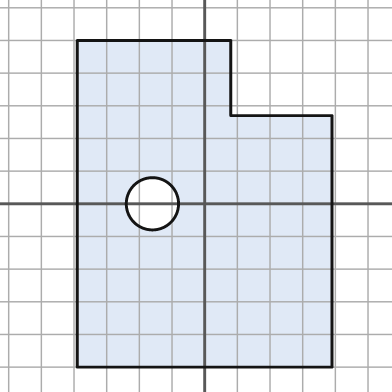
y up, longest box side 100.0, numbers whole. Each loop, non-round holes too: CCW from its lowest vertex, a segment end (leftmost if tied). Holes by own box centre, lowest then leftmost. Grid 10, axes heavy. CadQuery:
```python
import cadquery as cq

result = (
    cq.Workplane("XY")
    .moveTo(-39.0, -50.0)
    .lineTo(39.0, -50.0)
    .lineTo(39.0, 27.0)
    .lineTo(8.0, 27.0)
    .lineTo(8.0, 50.0)
    .lineTo(-39.0, 50.0)
    .close()
    .moveTo(-16.0, 0.0)
    .circle(8.0)
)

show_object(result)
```